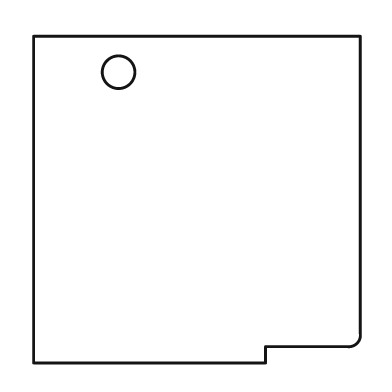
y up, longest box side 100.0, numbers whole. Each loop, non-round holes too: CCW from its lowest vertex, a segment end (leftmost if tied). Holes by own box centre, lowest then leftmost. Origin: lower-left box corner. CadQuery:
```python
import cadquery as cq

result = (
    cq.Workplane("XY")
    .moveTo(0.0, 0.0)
    .lineTo(71.0, 0.0)
    .lineTo(71.0, 5.0)
    .lineTo(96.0, 5.0)
    .threePointArc((99.0, 6.0), (100.0, 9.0))
    .lineTo(100.0, 100.0)
    .lineTo(0.0, 100.0)
    .close()
    .moveTo(26.0, 89.0)
    .circle(5.0)
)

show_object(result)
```